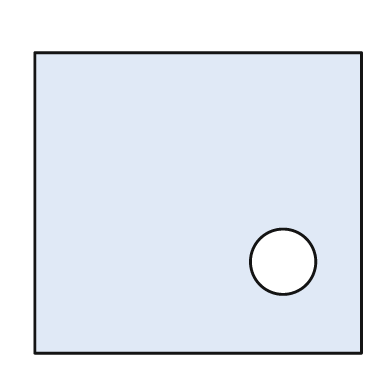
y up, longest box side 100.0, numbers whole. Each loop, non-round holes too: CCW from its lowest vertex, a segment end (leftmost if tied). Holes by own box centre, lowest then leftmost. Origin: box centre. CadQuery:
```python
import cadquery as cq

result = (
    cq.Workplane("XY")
    .moveTo(-50.0, -46.0)
    .lineTo(50.0, -46.0)
    .lineTo(50.0, 46.0)
    .lineTo(-50.0, 46.0)
    .close()
    .moveTo(26.0, -18.0)
    .circle(10.0)
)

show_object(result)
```